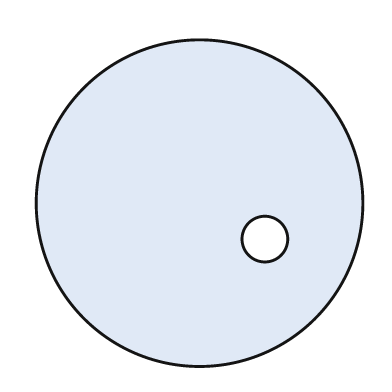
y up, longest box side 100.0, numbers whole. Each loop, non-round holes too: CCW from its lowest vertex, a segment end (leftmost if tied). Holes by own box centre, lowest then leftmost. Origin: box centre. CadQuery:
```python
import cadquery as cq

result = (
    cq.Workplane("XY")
    .moveTo(0.0, 0.0)
    .circle(50.0)
    .moveTo(20.0, -11.0)
    .circle(7.0)
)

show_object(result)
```